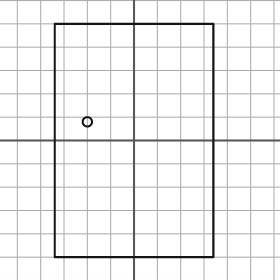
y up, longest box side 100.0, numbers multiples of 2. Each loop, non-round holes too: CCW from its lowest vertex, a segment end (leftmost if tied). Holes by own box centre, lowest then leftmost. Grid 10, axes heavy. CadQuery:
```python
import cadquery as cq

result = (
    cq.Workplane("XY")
    .moveTo(-34.0, -50.0)
    .lineTo(34.0, -50.0)
    .lineTo(34.0, 50.0)
    .lineTo(-34.0, 50.0)
    .close()
    .moveTo(-20.0, 8.0)
    .circle(2.0)
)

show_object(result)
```